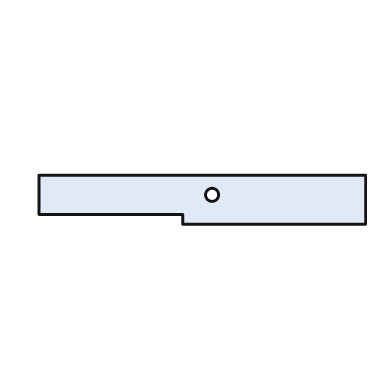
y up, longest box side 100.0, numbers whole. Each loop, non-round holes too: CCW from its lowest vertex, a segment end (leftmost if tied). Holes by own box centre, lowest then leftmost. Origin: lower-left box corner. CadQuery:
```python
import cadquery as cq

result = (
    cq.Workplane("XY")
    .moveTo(44.0, 0.0)
    .lineTo(100.0, 0.0)
    .lineTo(100.0, 15.0)
    .lineTo(0.0, 15.0)
    .lineTo(0.0, 3.0)
    .lineTo(44.0, 3.0)
    .close()
    .moveTo(53.0, 9.0)
    .circle(2.0)
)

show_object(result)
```